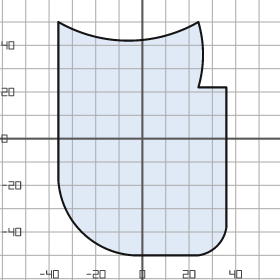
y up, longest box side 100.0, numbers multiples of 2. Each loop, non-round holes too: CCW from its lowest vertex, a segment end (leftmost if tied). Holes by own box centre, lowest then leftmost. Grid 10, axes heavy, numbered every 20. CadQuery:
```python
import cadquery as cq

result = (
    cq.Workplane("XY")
    .moveTo(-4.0, -50.0)
    .lineTo(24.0, -50.0)
    .threePointArc((32.0, -46.0), (36.0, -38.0))
    .lineTo(36.0, 22.0)
    .lineTo(24.0, 22.0)
    .threePointArc((26.0, 36.0), (24.0, 50.0))
    .threePointArc((-6.0, 42.0), (-36.0, 50.0))
    .lineTo(-36.0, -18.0)
    .threePointArc((-26.0, -40.0), (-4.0, -50.0))
    .close()
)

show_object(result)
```